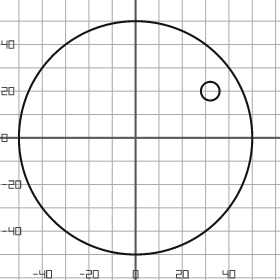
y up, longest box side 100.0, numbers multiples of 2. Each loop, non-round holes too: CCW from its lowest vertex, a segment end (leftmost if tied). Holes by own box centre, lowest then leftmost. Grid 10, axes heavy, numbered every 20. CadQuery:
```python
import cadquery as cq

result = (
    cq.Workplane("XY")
    .moveTo(0.0, 0.0)
    .circle(50.0)
    .moveTo(32.0, 20.0)
    .circle(4.0)
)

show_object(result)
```